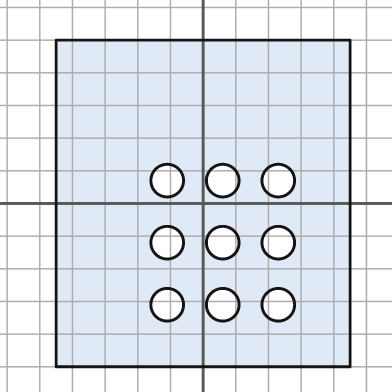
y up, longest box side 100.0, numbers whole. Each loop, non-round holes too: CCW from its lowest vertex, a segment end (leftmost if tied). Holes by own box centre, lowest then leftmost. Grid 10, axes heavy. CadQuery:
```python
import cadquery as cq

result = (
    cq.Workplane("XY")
    .moveTo(-45.0, -50.0)
    .lineTo(45.0, -50.0)
    .lineTo(45.0, 50.0)
    .lineTo(-45.0, 50.0)
    .close()
    .moveTo(-11.0, -31.0)
    .circle(5.0)
    .moveTo(6.0, -31.0)
    .circle(5.0)
    .moveTo(23.0, -31.0)
    .circle(5.0)
    .moveTo(-11.0, -12.0)
    .circle(5.0)
    .moveTo(6.0, -12.0)
    .circle(5.0)
    .moveTo(23.0, -12.0)
    .circle(5.0)
    .moveTo(-11.0, 7.0)
    .circle(5.0)
    .moveTo(6.0, 7.0)
    .circle(5.0)
    .moveTo(23.0, 7.0)
    .circle(5.0)
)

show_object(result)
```